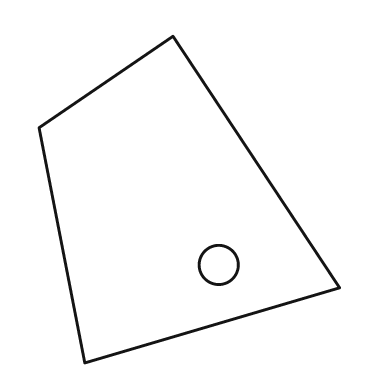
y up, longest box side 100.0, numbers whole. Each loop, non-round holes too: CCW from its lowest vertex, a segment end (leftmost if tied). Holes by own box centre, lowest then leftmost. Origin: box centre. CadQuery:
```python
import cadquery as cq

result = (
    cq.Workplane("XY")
    .moveTo(-32.0, -50.0)
    .lineTo(46.0, -27.0)
    .lineTo(-5.0, 50.0)
    .lineTo(-46.0, 22.0)
    .close()
    .moveTo(9.0, -20.0)
    .circle(6.0)
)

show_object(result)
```